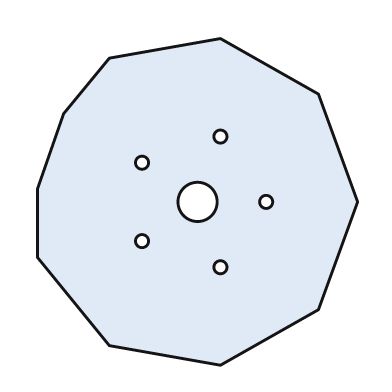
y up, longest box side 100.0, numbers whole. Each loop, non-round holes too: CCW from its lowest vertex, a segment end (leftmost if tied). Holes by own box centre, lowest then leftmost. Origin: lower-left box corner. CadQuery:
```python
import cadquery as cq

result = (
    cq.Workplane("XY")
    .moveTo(56.0, 0.0)
    .lineTo(86.0, 17.0)
    .lineTo(98.0, 50.0)
    .lineTo(86.0, 83.0)
    .lineTo(56.0, 100.0)
    .lineTo(22.0, 94.0)
    .lineTo(8.0, 77.0)
    .lineTo(0.0, 54.0)
    .lineTo(0.0, 33.0)
    .lineTo(22.0, 6.0)
    .close()
    .moveTo(56.0, 30.0)
    .circle(2.0)
    .moveTo(32.0, 38.0)
    .circle(2.0)
    .moveTo(49.0, 50.0)
    .circle(6.0)
    .moveTo(70.0, 50.0)
    .circle(2.0)
    .moveTo(32.0, 62.0)
    .circle(2.0)
    .moveTo(56.0, 70.0)
    .circle(2.0)
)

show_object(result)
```